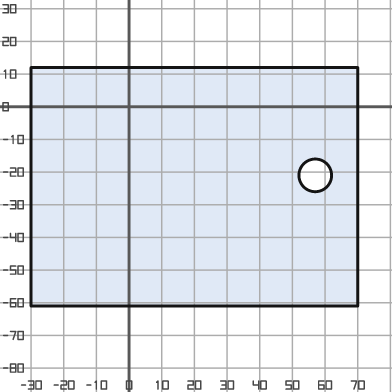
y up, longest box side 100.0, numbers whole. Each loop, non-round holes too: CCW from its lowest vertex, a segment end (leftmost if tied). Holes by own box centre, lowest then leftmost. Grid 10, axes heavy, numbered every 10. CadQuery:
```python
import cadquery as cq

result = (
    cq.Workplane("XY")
    .moveTo(-30.0, -61.0)
    .lineTo(70.0, -61.0)
    .lineTo(70.0, 12.0)
    .lineTo(-30.0, 12.0)
    .close()
    .moveTo(57.0, -21.0)
    .circle(5.0)
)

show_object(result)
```